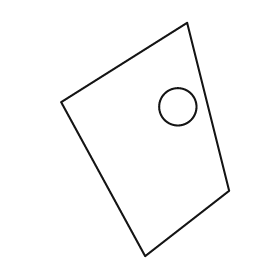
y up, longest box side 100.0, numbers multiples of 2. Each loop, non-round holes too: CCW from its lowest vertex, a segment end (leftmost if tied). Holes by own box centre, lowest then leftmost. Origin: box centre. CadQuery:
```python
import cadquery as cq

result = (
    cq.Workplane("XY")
    .moveTo(0.0, -50.0)
    .lineTo(36.0, -22.0)
    .lineTo(18.0, 50.0)
    .lineTo(-36.0, 16.0)
    .close()
    .moveTo(14.0, 14.0)
    .circle(8.0)
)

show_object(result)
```